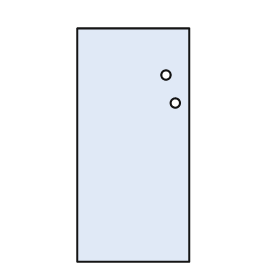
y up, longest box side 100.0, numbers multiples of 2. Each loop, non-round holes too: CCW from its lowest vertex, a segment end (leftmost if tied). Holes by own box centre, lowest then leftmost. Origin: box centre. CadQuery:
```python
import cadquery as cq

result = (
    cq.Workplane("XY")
    .moveTo(-24.0, -50.0)
    .lineTo(24.0, -50.0)
    .lineTo(24.0, 50.0)
    .lineTo(-24.0, 50.0)
    .close()
    .moveTo(18.0, 18.0)
    .circle(2.0)
    .moveTo(14.0, 30.0)
    .circle(2.0)
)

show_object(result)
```